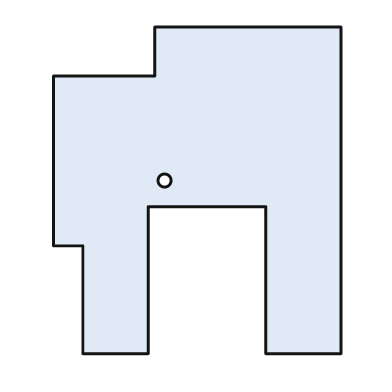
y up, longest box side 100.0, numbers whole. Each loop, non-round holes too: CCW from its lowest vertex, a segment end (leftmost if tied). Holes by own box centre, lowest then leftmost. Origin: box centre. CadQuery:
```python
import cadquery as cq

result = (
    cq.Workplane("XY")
    .moveTo(-35.0, -50.0)
    .lineTo(-15.0, -50.0)
    .lineTo(-15.0, -5.0)
    .lineTo(21.0, -5.0)
    .lineTo(21.0, -50.0)
    .lineTo(44.0, -50.0)
    .lineTo(44.0, 50.0)
    .lineTo(-13.0, 50.0)
    .lineTo(-13.0, 35.0)
    .lineTo(-44.0, 35.0)
    .lineTo(-44.0, -17.0)
    .lineTo(-35.0, -17.0)
    .close()
    .moveTo(-10.0, 3.0)
    .circle(2.0)
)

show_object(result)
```